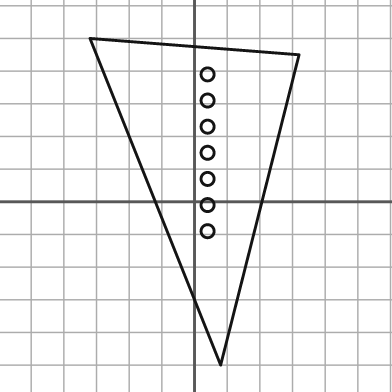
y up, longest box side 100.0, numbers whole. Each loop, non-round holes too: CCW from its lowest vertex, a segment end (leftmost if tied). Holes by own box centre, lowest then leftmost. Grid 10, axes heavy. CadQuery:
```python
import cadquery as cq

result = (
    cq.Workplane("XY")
    .moveTo(8.0, -50.0)
    .lineTo(32.0, 45.0)
    .lineTo(-32.0, 50.0)
    .close()
    .moveTo(4.0, -9.0)
    .circle(2.0)
    .moveTo(4.0, -1.0)
    .circle(2.0)
    .moveTo(4.0, 7.0)
    .circle(2.0)
    .moveTo(4.0, 15.0)
    .circle(2.0)
    .moveTo(4.0, 23.0)
    .circle(2.0)
    .moveTo(4.0, 31.0)
    .circle(2.0)
    .moveTo(4.0, 39.0)
    .circle(2.0)
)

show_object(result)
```